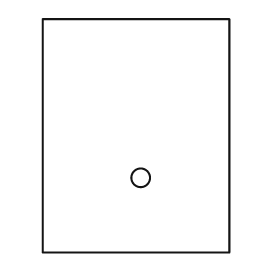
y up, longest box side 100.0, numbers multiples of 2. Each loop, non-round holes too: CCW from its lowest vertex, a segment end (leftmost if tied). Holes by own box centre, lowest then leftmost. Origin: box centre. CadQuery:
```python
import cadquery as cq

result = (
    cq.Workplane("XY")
    .moveTo(-40.0, -50.0)
    .lineTo(40.0, -50.0)
    .lineTo(40.0, 50.0)
    .lineTo(-40.0, 50.0)
    .close()
    .moveTo(2.0, -18.0)
    .circle(4.0)
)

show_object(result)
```